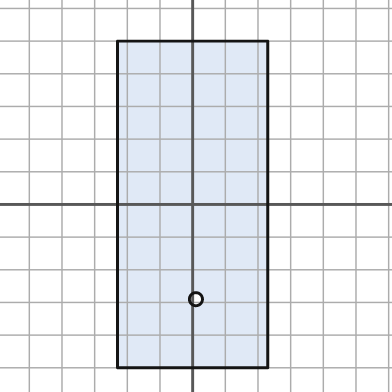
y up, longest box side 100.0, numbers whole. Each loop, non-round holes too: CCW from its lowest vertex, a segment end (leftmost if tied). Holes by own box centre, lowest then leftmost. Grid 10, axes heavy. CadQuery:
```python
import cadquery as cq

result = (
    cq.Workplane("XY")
    .moveTo(-23.0, -50.0)
    .lineTo(23.0, -50.0)
    .lineTo(23.0, 50.0)
    .lineTo(-23.0, 50.0)
    .close()
    .moveTo(1.0, -29.0)
    .circle(2.0)
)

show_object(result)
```